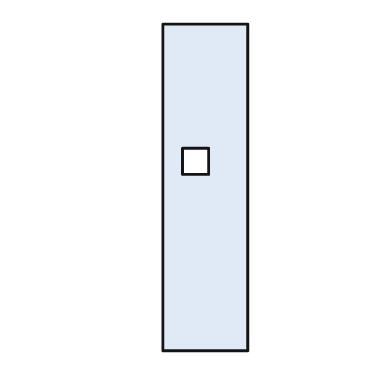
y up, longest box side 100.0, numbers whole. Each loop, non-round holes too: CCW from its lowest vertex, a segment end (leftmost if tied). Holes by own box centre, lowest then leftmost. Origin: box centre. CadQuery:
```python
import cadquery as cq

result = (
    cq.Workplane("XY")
    .moveTo(-13.0, -50.0)
    .lineTo(13.0, -50.0)
    .lineTo(13.0, 50.0)
    .lineTo(-13.0, 50.0)
    .close()
    .moveTo(-7.0, 4.0)
    .lineTo(1.0, 4.0)
    .lineTo(1.0, 12.0)
    .lineTo(-7.0, 12.0)
    .close()
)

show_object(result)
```